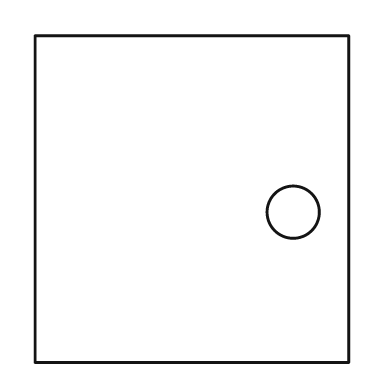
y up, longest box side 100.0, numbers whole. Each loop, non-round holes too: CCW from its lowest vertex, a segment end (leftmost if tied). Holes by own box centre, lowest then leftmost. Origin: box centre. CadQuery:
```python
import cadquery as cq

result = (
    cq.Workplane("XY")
    .moveTo(-48.0, -50.0)
    .lineTo(48.0, -50.0)
    .lineTo(48.0, 50.0)
    .lineTo(-48.0, 50.0)
    .close()
    .moveTo(31.0, -4.0)
    .circle(8.0)
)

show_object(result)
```